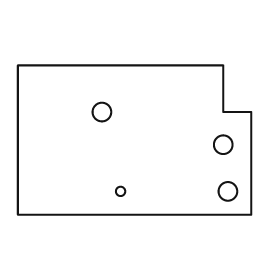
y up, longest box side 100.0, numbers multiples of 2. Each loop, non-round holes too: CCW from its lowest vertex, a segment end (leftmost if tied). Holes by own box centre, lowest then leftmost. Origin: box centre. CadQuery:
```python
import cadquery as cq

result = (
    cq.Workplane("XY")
    .moveTo(-50.0, -32.0)
    .lineTo(50.0, -32.0)
    .lineTo(50.0, 12.0)
    .lineTo(38.0, 12.0)
    .lineTo(38.0, 32.0)
    .lineTo(-50.0, 32.0)
    .close()
    .moveTo(-6.0, -22.0)
    .circle(2.0)
    .moveTo(40.0, -22.0)
    .circle(4.0)
    .moveTo(38.0, -2.0)
    .circle(4.0)
    .moveTo(-14.0, 12.0)
    .circle(4.0)
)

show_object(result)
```